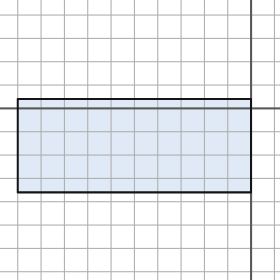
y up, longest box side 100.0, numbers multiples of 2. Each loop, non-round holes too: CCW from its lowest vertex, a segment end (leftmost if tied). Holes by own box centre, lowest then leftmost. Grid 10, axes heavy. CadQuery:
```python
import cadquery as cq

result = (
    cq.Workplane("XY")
    .moveTo(-100.0, -36.0)
    .lineTo(0.0, -36.0)
    .lineTo(0.0, 4.0)
    .lineTo(-100.0, 4.0)
    .close()
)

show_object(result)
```